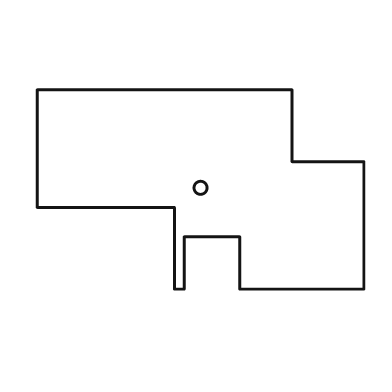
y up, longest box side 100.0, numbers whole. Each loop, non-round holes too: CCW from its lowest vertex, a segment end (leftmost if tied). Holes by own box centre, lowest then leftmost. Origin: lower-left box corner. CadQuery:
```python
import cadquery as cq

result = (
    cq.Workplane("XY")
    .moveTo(42.0, 0.0)
    .lineTo(45.0, 0.0)
    .lineTo(45.0, 16.0)
    .lineTo(62.0, 16.0)
    .lineTo(62.0, 0.0)
    .lineTo(100.0, 0.0)
    .lineTo(100.0, 39.0)
    .lineTo(78.0, 39.0)
    .lineTo(78.0, 61.0)
    .lineTo(0.0, 61.0)
    .lineTo(0.0, 25.0)
    .lineTo(42.0, 25.0)
    .close()
    .moveTo(50.0, 31.0)
    .circle(2.0)
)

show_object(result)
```